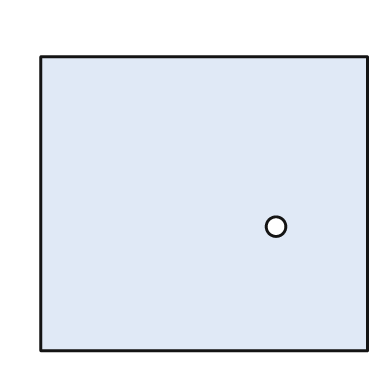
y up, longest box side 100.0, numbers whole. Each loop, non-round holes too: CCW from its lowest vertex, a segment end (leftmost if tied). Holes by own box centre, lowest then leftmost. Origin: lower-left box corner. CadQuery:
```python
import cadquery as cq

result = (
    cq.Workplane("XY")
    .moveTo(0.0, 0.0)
    .lineTo(100.0, 0.0)
    .lineTo(100.0, 90.0)
    .lineTo(0.0, 90.0)
    .close()
    .moveTo(72.0, 38.0)
    .circle(3.0)
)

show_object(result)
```